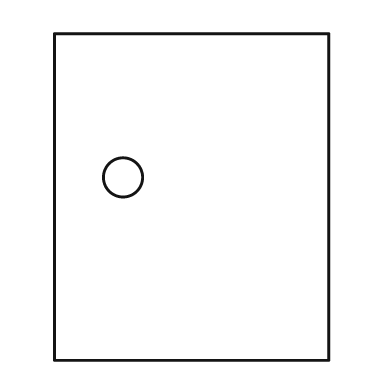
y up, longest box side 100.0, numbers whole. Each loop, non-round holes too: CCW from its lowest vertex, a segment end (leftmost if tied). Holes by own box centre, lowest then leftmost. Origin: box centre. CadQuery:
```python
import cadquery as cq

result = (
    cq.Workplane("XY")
    .moveTo(-42.0, -50.0)
    .lineTo(42.0, -50.0)
    .lineTo(42.0, 50.0)
    .lineTo(-42.0, 50.0)
    .close()
    .moveTo(-21.0, 6.0)
    .circle(6.0)
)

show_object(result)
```